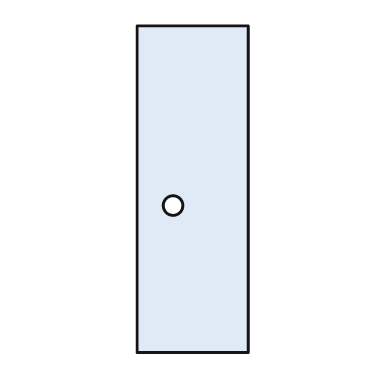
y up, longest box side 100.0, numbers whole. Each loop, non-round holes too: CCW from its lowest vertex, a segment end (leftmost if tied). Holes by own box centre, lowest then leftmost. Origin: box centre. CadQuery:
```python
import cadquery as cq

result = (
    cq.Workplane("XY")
    .moveTo(-17.0, -50.0)
    .lineTo(17.0, -50.0)
    .lineTo(17.0, 50.0)
    .lineTo(-17.0, 50.0)
    .close()
    .moveTo(-6.0, -5.0)
    .circle(3.0)
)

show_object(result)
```